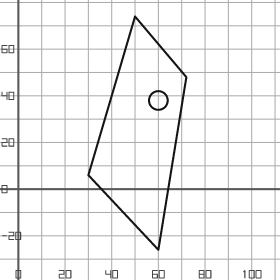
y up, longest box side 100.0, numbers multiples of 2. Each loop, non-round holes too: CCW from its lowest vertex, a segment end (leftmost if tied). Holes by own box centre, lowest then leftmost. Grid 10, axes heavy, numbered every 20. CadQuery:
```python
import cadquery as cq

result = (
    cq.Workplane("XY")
    .moveTo(60.0, -26.0)
    .lineTo(72.0, 48.0)
    .lineTo(50.0, 74.0)
    .lineTo(30.0, 6.0)
    .close()
    .moveTo(60.0, 38.0)
    .circle(4.0)
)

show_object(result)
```